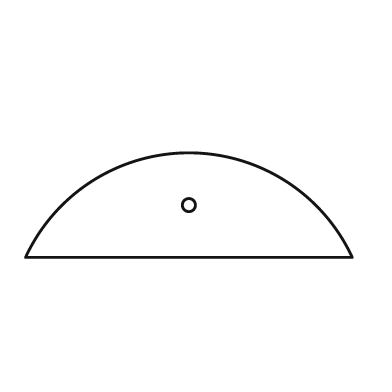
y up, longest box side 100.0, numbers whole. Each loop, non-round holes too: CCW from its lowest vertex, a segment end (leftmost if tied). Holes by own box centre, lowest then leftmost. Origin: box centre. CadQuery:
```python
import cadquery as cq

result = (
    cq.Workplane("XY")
    .moveTo(-50.0, -16.0)
    .lineTo(50.0, -16.0)
    .threePointArc((0.0, 16.0), (-50.0, -16.0))
    .close()
    .moveTo(0.0, 0.0)
    .circle(2.0)
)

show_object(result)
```